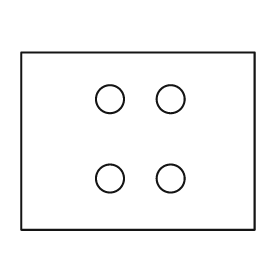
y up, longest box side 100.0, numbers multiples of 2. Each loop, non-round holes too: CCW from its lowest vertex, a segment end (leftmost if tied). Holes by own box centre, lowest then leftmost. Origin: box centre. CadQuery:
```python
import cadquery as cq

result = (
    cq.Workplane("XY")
    .moveTo(-50.0, -38.0)
    .lineTo(50.0, -38.0)
    .lineTo(50.0, 38.0)
    .lineTo(-50.0, 38.0)
    .close()
    .moveTo(-12.0, -16.0)
    .circle(6.0)
    .moveTo(14.0, -16.0)
    .circle(6.0)
    .moveTo(-12.0, 18.0)
    .circle(6.0)
    .moveTo(14.0, 18.0)
    .circle(6.0)
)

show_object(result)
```